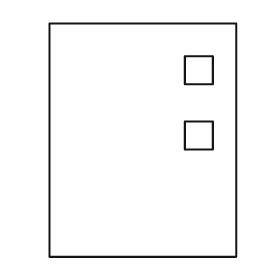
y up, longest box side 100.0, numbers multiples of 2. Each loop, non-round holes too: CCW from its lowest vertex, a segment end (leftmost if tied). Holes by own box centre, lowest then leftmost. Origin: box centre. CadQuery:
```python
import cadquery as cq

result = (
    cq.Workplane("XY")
    .moveTo(-40.0, -50.0)
    .lineTo(40.0, -50.0)
    .lineTo(40.0, 50.0)
    .lineTo(-40.0, 50.0)
    .close()
    .moveTo(18.0, -4.0)
    .lineTo(30.0, -4.0)
    .lineTo(30.0, 8.0)
    .lineTo(18.0, 8.0)
    .close()
    .moveTo(18.0, 24.0)
    .lineTo(30.0, 24.0)
    .lineTo(30.0, 36.0)
    .lineTo(18.0, 36.0)
    .close()
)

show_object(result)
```